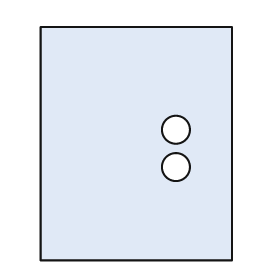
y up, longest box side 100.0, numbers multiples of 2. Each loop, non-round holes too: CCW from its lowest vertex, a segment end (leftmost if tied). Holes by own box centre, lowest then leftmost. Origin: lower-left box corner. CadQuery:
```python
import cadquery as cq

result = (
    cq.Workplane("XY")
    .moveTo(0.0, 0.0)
    .lineTo(82.0, 0.0)
    .lineTo(82.0, 100.0)
    .lineTo(0.0, 100.0)
    .close()
    .moveTo(58.0, 40.0)
    .circle(6.0)
    .moveTo(58.0, 56.0)
    .circle(6.0)
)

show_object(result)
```